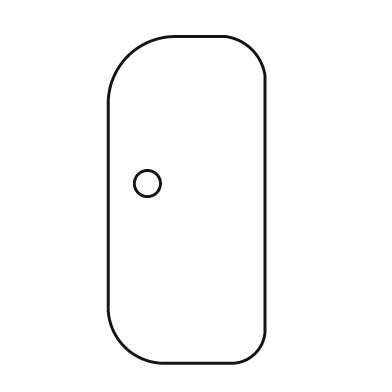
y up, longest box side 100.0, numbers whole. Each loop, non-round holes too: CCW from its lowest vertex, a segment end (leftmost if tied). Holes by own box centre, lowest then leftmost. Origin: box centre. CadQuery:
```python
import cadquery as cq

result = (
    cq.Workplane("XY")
    .moveTo(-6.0, -50.0)
    .lineTo(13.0, -50.0)
    .threePointArc((21.0, -47.0), (24.0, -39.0))
    .lineTo(24.0, 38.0)
    .threePointArc((20.0, 46.0), (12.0, 50.0))
    .lineTo(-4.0, 50.0)
    .threePointArc((-18.0, 44.0), (-24.0, 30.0))
    .lineTo(-24.0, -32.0)
    .threePointArc((-19.0, -45.0), (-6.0, -50.0))
    .close()
    .moveTo(-12.0, 5.0)
    .circle(4.0)
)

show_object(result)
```